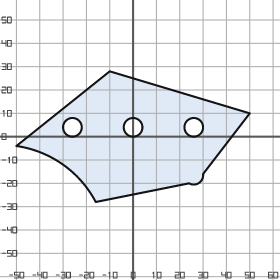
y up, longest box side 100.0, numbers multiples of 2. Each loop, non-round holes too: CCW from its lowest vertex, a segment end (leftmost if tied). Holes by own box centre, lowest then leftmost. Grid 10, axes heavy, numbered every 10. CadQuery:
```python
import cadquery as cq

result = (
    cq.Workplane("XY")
    .moveTo(-16.0, -28.0)
    .lineTo(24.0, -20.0)
    .threePointArc((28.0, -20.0), (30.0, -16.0))
    .lineTo(50.0, 10.0)
    .lineTo(-10.0, 28.0)
    .lineTo(-50.0, -4.0)
    .threePointArc((-30.0, -12.0), (-16.0, -28.0))
    .close()
    .moveTo(-26.0, 4.0)
    .circle(4.0)
    .moveTo(0.0, 4.0)
    .circle(4.0)
    .moveTo(26.0, 4.0)
    .circle(4.0)
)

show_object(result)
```